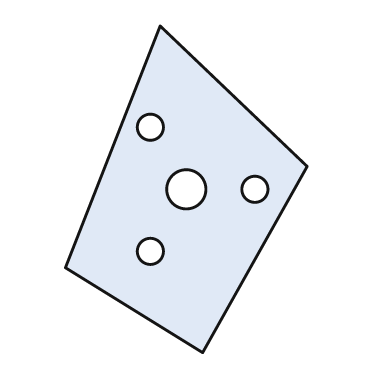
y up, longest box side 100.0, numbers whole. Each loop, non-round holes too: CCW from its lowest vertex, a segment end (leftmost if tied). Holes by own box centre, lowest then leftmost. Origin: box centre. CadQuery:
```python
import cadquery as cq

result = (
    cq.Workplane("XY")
    .moveTo(5.0, -50.0)
    .lineTo(37.0, 7.0)
    .lineTo(-8.0, 50.0)
    .lineTo(-37.0, -24.0)
    .close()
    .moveTo(-11.0, -19.0)
    .circle(4.0)
    .moveTo(0.0, 0.0)
    .circle(6.0)
    .moveTo(21.0, 0.0)
    .circle(4.0)
    .moveTo(-11.0, 19.0)
    .circle(4.0)
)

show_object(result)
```